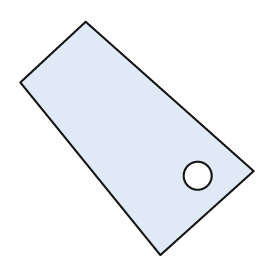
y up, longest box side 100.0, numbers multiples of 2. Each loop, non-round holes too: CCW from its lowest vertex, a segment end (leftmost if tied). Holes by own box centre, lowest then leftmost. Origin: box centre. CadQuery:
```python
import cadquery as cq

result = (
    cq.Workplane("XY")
    .moveTo(10.0, -50.0)
    .lineTo(50.0, -14.0)
    .lineTo(-22.0, 50.0)
    .lineTo(-50.0, 24.0)
    .close()
    .moveTo(26.0, -16.0)
    .circle(6.0)
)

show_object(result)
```